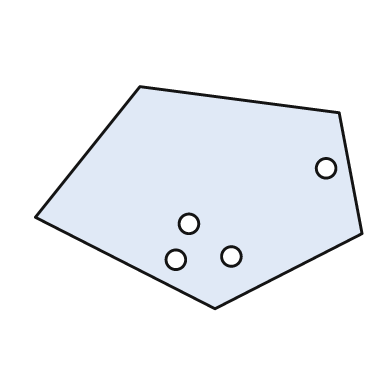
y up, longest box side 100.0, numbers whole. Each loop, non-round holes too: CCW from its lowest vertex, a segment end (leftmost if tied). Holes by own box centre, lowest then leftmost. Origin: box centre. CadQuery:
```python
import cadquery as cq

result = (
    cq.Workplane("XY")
    .moveTo(5.0, -34.0)
    .lineTo(50.0, -11.0)
    .lineTo(43.0, 26.0)
    .lineTo(-18.0, 34.0)
    .lineTo(-50.0, -6.0)
    .close()
    .moveTo(-7.0, -19.0)
    .circle(3.0)
    .moveTo(10.0, -18.0)
    .circle(3.0)
    .moveTo(-3.0, -8.0)
    .circle(3.0)
    .moveTo(39.0, 9.0)
    .circle(3.0)
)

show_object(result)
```